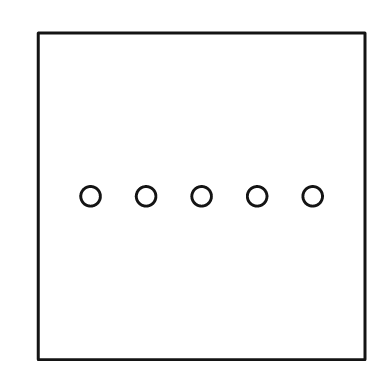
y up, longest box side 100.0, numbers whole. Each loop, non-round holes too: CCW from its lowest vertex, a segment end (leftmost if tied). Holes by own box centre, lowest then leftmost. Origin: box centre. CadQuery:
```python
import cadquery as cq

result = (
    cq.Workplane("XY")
    .moveTo(-50.0, -50.0)
    .lineTo(50.0, -50.0)
    .lineTo(50.0, 50.0)
    .lineTo(-50.0, 50.0)
    .close()
    .moveTo(-34.0, 0.0)
    .circle(3.0)
    .moveTo(-17.0, 0.0)
    .circle(3.0)
    .moveTo(0.0, 0.0)
    .circle(3.0)
    .moveTo(17.0, 0.0)
    .circle(3.0)
    .moveTo(34.0, 0.0)
    .circle(3.0)
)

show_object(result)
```